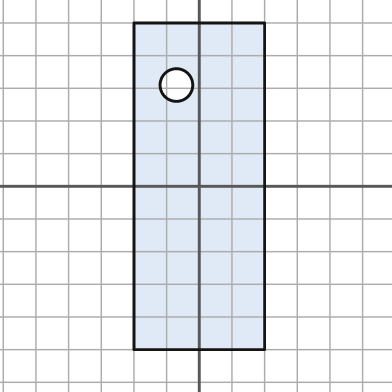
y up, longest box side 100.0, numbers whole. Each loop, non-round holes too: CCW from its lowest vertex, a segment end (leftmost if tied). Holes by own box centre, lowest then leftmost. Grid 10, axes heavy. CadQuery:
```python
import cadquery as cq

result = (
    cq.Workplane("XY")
    .moveTo(-20.0, -50.0)
    .lineTo(20.0, -50.0)
    .lineTo(20.0, 50.0)
    .lineTo(-20.0, 50.0)
    .close()
    .moveTo(-7.0, 31.0)
    .circle(5.0)
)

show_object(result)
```